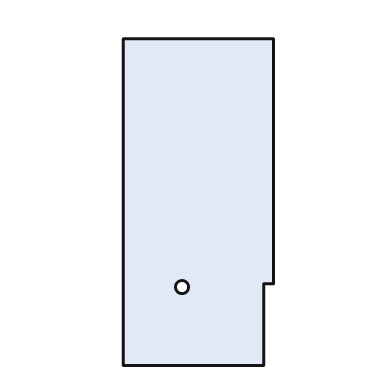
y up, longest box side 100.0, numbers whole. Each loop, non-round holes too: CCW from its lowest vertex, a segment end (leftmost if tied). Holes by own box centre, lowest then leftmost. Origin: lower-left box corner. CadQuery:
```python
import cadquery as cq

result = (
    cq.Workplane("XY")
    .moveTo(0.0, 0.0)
    .lineTo(43.0, 0.0)
    .lineTo(43.0, 25.0)
    .lineTo(46.0, 25.0)
    .lineTo(46.0, 100.0)
    .lineTo(0.0, 100.0)
    .close()
    .moveTo(18.0, 24.0)
    .circle(2.0)
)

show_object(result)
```